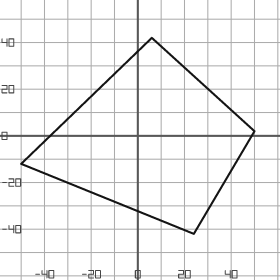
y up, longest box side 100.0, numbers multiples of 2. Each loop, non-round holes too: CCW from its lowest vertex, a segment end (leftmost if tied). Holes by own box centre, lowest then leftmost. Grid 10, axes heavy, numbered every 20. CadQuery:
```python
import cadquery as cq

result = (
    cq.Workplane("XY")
    .moveTo(24.0, -42.0)
    .lineTo(50.0, 2.0)
    .lineTo(6.0, 42.0)
    .lineTo(-50.0, -12.0)
    .close()
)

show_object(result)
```